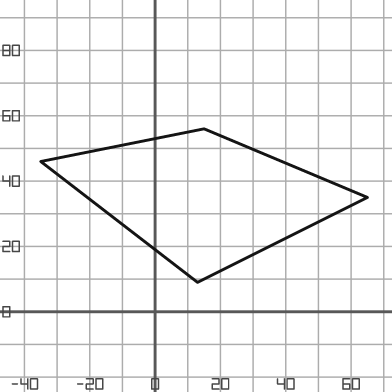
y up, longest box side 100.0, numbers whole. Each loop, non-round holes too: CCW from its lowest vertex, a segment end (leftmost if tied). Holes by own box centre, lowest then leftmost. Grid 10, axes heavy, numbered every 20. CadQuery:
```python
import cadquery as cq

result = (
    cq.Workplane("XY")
    .moveTo(13.0, 9.0)
    .lineTo(65.0, 35.0)
    .lineTo(15.0, 56.0)
    .lineTo(-35.0, 46.0)
    .close()
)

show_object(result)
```